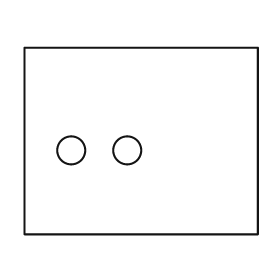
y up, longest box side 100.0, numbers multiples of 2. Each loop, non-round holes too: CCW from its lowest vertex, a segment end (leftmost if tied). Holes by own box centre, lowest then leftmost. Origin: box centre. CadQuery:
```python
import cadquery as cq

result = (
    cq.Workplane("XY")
    .moveTo(-50.0, -40.0)
    .lineTo(50.0, -40.0)
    .lineTo(50.0, 40.0)
    .lineTo(-50.0, 40.0)
    .close()
    .moveTo(-30.0, -4.0)
    .circle(6.0)
    .moveTo(-6.0, -4.0)
    .circle(6.0)
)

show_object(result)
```